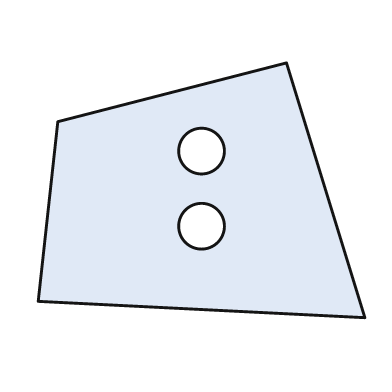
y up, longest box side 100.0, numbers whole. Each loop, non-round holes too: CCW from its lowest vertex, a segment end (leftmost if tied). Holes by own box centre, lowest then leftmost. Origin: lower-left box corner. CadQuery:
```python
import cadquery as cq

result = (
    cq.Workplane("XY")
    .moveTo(100.0, 0.0)
    .lineTo(76.0, 78.0)
    .lineTo(6.0, 60.0)
    .lineTo(0.0, 5.0)
    .close()
    .moveTo(50.0, 28.0)
    .circle(7.0)
    .moveTo(50.0, 51.0)
    .circle(7.0)
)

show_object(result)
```